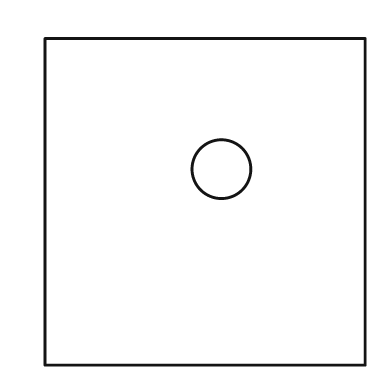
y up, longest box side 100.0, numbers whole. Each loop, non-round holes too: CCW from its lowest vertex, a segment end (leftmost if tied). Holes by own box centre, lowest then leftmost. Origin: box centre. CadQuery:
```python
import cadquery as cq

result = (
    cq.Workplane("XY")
    .moveTo(-49.0, -50.0)
    .lineTo(49.0, -50.0)
    .lineTo(49.0, 50.0)
    .lineTo(-49.0, 50.0)
    .close()
    .moveTo(5.0, 10.0)
    .circle(9.0)
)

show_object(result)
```